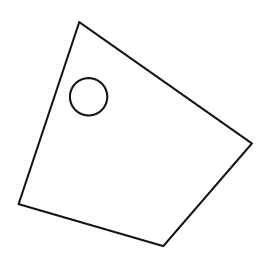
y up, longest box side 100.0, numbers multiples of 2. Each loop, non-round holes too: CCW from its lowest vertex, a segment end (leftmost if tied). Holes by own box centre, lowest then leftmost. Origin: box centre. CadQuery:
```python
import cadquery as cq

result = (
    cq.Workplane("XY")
    .moveTo(12.0, -48.0)
    .lineTo(50.0, -4.0)
    .lineTo(-24.0, 48.0)
    .lineTo(-50.0, -30.0)
    .close()
    .moveTo(-20.0, 16.0)
    .circle(8.0)
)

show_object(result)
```